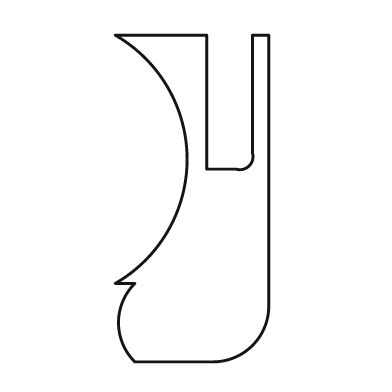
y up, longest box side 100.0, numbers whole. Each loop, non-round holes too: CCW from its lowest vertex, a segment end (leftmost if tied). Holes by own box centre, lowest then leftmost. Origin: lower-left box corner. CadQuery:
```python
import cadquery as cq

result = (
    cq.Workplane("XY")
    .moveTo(6.0, 0.0)
    .lineTo(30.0, 0.0)
    .threePointArc((42.0, 5.0), (47.0, 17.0))
    .lineTo(47.0, 100.0)
    .lineTo(42.0, 100.0)
    .lineTo(42.0, 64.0)
    .threePointArc((41.0, 60.0), (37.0, 59.0))
    .lineTo(28.0, 59.0)
    .lineTo(28.0, 100.0)
    .lineTo(0.0, 100.0)
    .threePointArc((22.0, 62.0), (0.0, 24.0))
    .lineTo(6.0, 24.0)
    .threePointArc((1.0, 12.0), (6.0, 0.0))
    .close()
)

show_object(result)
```